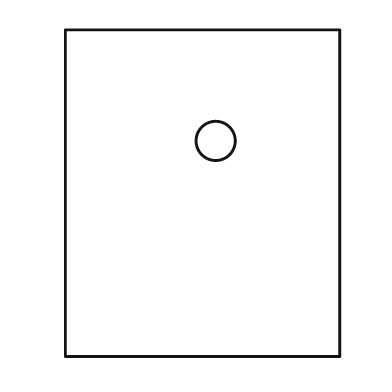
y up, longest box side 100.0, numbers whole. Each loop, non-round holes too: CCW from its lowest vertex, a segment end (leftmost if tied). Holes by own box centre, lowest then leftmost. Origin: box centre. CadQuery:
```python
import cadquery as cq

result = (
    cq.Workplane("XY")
    .moveTo(-42.0, -50.0)
    .lineTo(42.0, -50.0)
    .lineTo(42.0, 50.0)
    .lineTo(-42.0, 50.0)
    .close()
    .moveTo(4.0, 16.0)
    .circle(6.0)
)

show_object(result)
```